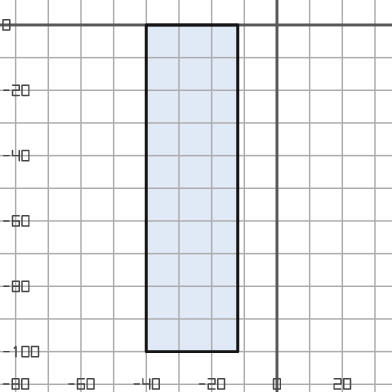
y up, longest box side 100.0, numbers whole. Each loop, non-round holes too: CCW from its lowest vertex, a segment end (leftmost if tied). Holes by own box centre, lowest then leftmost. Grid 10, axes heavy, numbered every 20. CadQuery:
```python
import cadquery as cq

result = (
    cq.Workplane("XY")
    .moveTo(-40.0, -100.0)
    .lineTo(-12.0, -100.0)
    .lineTo(-12.0, 0.0)
    .lineTo(-40.0, 0.0)
    .close()
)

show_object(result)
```